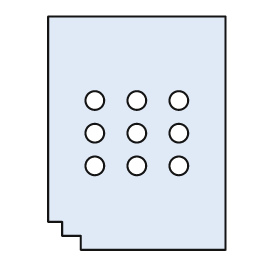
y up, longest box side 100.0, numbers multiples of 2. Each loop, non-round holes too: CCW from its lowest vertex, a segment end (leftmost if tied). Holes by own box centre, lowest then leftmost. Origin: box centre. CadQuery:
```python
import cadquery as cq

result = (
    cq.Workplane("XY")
    .moveTo(-24.0, -50.0)
    .lineTo(38.0, -50.0)
    .lineTo(38.0, 50.0)
    .lineTo(-38.0, 50.0)
    .lineTo(-38.0, -38.0)
    .lineTo(-32.0, -38.0)
    .lineTo(-32.0, -44.0)
    .lineTo(-24.0, -44.0)
    .close()
    .moveTo(-18.0, -14.0)
    .circle(4.0)
    .moveTo(0.0, -14.0)
    .circle(4.0)
    .moveTo(18.0, -14.0)
    .circle(4.0)
    .moveTo(-18.0, 0.0)
    .circle(4.0)
    .moveTo(0.0, 0.0)
    .circle(4.0)
    .moveTo(18.0, 0.0)
    .circle(4.0)
    .moveTo(-18.0, 14.0)
    .circle(4.0)
    .moveTo(0.0, 14.0)
    .circle(4.0)
    .moveTo(18.0, 14.0)
    .circle(4.0)
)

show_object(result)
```